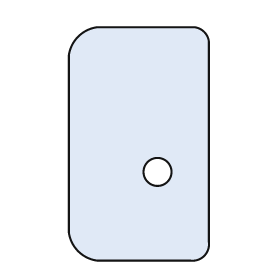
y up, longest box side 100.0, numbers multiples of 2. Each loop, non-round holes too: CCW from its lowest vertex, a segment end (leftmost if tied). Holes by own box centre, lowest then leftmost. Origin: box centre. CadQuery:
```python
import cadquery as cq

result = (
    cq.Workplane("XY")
    .moveTo(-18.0, -50.0)
    .lineTo(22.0, -50.0)
    .threePointArc((28.0, -48.0), (30.0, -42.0))
    .lineTo(30.0, 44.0)
    .threePointArc((28.0, 48.0), (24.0, 50.0))
    .lineTo(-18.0, 50.0)
    .threePointArc((-26.0, 46.0), (-30.0, 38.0))
    .lineTo(-30.0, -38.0)
    .threePointArc((-26.0, -46.0), (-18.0, -50.0))
    .close()
    .moveTo(8.0, -12.0)
    .circle(6.0)
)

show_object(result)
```